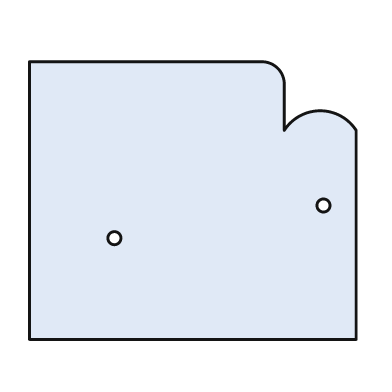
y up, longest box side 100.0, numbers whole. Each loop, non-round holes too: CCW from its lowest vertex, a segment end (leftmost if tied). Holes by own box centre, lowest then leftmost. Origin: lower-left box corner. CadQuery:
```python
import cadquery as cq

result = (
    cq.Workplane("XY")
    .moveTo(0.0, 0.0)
    .lineTo(100.0, 0.0)
    .lineTo(100.0, 64.0)
    .threePointArc((89.0, 70.0), (78.0, 64.0))
    .lineTo(78.0, 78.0)
    .threePointArc((76.0, 83.0), (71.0, 85.0))
    .lineTo(0.0, 85.0)
    .close()
    .moveTo(26.0, 31.0)
    .circle(2.0)
    .moveTo(90.0, 41.0)
    .circle(2.0)
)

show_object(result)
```